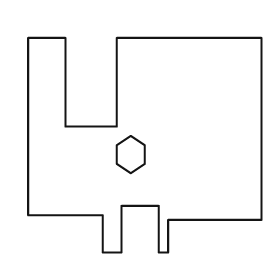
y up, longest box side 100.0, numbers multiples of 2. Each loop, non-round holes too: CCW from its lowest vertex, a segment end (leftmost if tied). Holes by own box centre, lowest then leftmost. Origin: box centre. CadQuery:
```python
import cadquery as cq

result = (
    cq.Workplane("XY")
    .moveTo(-18.0, -46.0)
    .lineTo(-10.0, -46.0)
    .lineTo(-10.0, -26.0)
    .lineTo(6.0, -26.0)
    .lineTo(6.0, -46.0)
    .lineTo(10.0, -46.0)
    .lineTo(10.0, -32.0)
    .lineTo(50.0, -32.0)
    .lineTo(50.0, 46.0)
    .lineTo(-12.0, 46.0)
    .lineTo(-12.0, 8.0)
    .lineTo(-34.0, 8.0)
    .lineTo(-34.0, 46.0)
    .lineTo(-50.0, 46.0)
    .lineTo(-50.0, -30.0)
    .lineTo(-18.0, -30.0)
    .close()
    .moveTo(-6.0, -12.0)
    .lineTo(0.0, -8.0)
    .lineTo(0.0, 0.0)
    .lineTo(-6.0, 4.0)
    .lineTo(-12.0, 0.0)
    .lineTo(-12.0, -8.0)
    .close()
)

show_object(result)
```